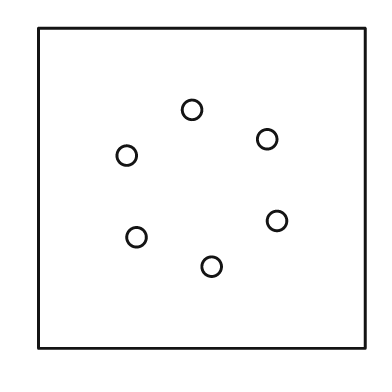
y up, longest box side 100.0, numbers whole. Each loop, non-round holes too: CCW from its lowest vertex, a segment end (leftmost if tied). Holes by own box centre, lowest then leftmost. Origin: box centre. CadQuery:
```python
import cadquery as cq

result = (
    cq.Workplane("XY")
    .moveTo(-50.0, -49.0)
    .lineTo(50.0, -49.0)
    .lineTo(50.0, 49.0)
    .lineTo(-50.0, 49.0)
    .close()
    .moveTo(3.0, -24.0)
    .circle(3.0)
    .moveTo(-20.0, -15.0)
    .circle(3.0)
    .moveTo(23.0, -10.0)
    .circle(3.0)
    .moveTo(-23.0, 10.0)
    .circle(3.0)
    .moveTo(20.0, 15.0)
    .circle(3.0)
    .moveTo(-3.0, 24.0)
    .circle(3.0)
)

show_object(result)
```